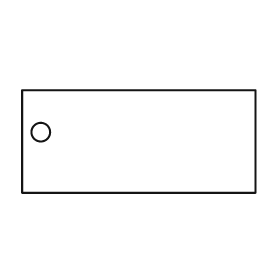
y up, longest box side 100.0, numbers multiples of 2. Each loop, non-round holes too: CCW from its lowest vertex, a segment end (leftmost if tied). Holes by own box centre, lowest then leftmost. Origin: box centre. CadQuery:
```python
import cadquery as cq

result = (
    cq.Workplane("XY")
    .moveTo(-50.0, -22.0)
    .lineTo(50.0, -22.0)
    .lineTo(50.0, 22.0)
    .lineTo(-50.0, 22.0)
    .close()
    .moveTo(-42.0, 4.0)
    .circle(4.0)
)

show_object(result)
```